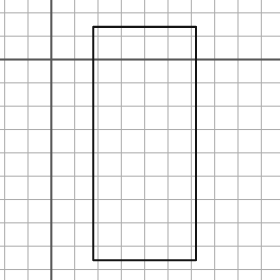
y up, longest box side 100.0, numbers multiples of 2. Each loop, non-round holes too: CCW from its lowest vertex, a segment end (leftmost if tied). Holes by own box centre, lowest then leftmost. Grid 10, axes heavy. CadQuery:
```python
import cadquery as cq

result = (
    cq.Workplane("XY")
    .moveTo(18.0, -86.0)
    .lineTo(62.0, -86.0)
    .lineTo(62.0, 14.0)
    .lineTo(18.0, 14.0)
    .close()
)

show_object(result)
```